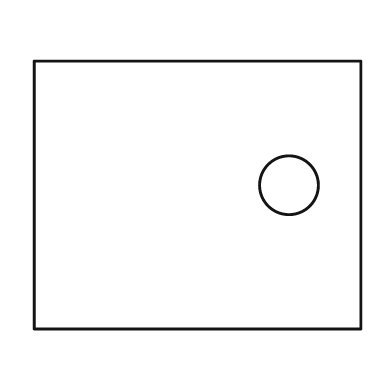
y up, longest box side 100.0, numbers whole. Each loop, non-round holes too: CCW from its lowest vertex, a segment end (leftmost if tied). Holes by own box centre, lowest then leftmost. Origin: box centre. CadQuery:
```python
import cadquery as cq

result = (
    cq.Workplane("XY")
    .moveTo(-50.0, -41.0)
    .lineTo(50.0, -41.0)
    .lineTo(50.0, 41.0)
    .lineTo(-50.0, 41.0)
    .close()
    .moveTo(28.0, 3.0)
    .circle(9.0)
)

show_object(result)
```